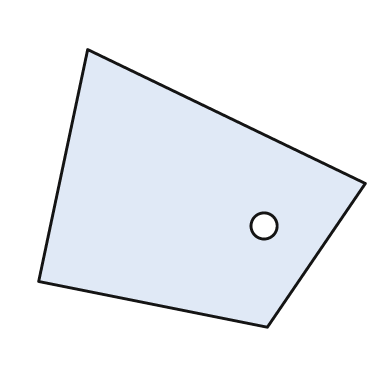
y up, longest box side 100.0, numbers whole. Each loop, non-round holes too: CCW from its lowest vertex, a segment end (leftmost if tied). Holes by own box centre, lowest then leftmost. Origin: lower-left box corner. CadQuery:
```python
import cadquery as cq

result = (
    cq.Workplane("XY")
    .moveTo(70.0, 0.0)
    .lineTo(100.0, 44.0)
    .lineTo(15.0, 85.0)
    .lineTo(0.0, 14.0)
    .close()
    .moveTo(69.0, 31.0)
    .circle(4.0)
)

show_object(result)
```